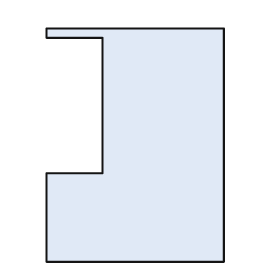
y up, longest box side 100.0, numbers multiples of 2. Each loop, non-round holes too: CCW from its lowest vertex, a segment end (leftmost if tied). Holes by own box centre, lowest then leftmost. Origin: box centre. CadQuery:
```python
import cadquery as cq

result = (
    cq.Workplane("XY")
    .moveTo(-38.0, -50.0)
    .lineTo(38.0, -50.0)
    .lineTo(38.0, 50.0)
    .lineTo(-38.0, 50.0)
    .lineTo(-38.0, 46.0)
    .lineTo(-14.0, 46.0)
    .lineTo(-14.0, -12.0)
    .lineTo(-38.0, -12.0)
    .close()
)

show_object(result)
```